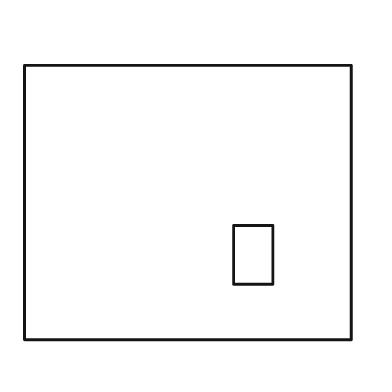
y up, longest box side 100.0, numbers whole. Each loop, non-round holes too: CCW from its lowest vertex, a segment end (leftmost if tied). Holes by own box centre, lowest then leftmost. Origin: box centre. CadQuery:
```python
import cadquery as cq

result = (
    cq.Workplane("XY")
    .moveTo(-50.0, -42.0)
    .lineTo(50.0, -42.0)
    .lineTo(50.0, 42.0)
    .lineTo(-50.0, 42.0)
    .close()
    .moveTo(14.0, -25.0)
    .lineTo(26.0, -25.0)
    .lineTo(26.0, -7.0)
    .lineTo(14.0, -7.0)
    .close()
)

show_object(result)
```